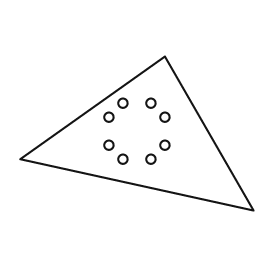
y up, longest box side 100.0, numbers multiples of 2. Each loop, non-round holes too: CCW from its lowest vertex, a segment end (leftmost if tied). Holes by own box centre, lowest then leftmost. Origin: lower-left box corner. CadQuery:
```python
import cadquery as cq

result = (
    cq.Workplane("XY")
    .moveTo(100.0, 0.0)
    .lineTo(62.0, 66.0)
    .lineTo(0.0, 22.0)
    .close()
    .moveTo(44.0, 22.0)
    .circle(2.0)
    .moveTo(56.0, 22.0)
    .circle(2.0)
    .moveTo(38.0, 28.0)
    .circle(2.0)
    .moveTo(62.0, 28.0)
    .circle(2.0)
    .moveTo(38.0, 40.0)
    .circle(2.0)
    .moveTo(62.0, 40.0)
    .circle(2.0)
    .moveTo(44.0, 46.0)
    .circle(2.0)
    .moveTo(56.0, 46.0)
    .circle(2.0)
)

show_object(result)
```